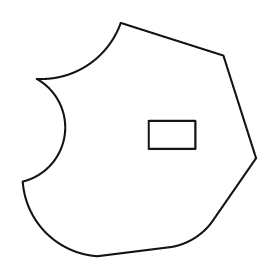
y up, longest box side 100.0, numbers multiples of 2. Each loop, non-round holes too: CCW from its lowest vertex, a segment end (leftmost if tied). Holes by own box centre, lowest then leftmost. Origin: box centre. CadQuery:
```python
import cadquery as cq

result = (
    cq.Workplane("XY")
    .moveTo(-18.0, -50.0)
    .lineTo(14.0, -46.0)
    .threePointArc((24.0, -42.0), (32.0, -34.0))
    .lineTo(50.0, -8.0)
    .lineTo(36.0, 36.0)
    .lineTo(-8.0, 50.0)
    .threePointArc((-22.0, 32.0), (-44.0, 26.0))
    .threePointArc((-32.0, 2.0), (-50.0, -18.0))
    .threePointArc((-40.0, -40.0), (-18.0, -50.0))
    .close()
    .moveTo(4.0, -4.0)
    .lineTo(24.0, -4.0)
    .lineTo(24.0, 8.0)
    .lineTo(4.0, 8.0)
    .close()
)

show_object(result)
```